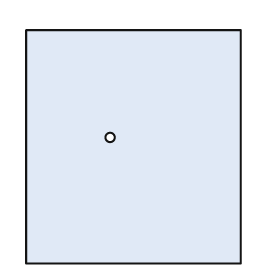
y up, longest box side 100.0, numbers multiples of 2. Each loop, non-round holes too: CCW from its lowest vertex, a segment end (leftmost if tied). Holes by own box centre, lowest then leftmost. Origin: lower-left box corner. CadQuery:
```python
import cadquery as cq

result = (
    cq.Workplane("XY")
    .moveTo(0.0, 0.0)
    .lineTo(92.0, 0.0)
    .lineTo(92.0, 100.0)
    .lineTo(0.0, 100.0)
    .close()
    .moveTo(36.0, 54.0)
    .circle(2.0)
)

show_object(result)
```